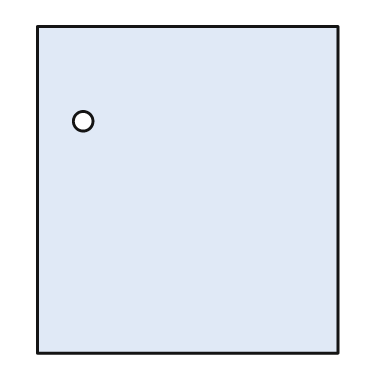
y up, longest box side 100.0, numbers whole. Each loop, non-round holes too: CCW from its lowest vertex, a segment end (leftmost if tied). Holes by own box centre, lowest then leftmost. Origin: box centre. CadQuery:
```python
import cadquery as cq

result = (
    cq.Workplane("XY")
    .moveTo(-46.0, -50.0)
    .lineTo(46.0, -50.0)
    .lineTo(46.0, 50.0)
    .lineTo(-46.0, 50.0)
    .close()
    .moveTo(-32.0, 21.0)
    .circle(3.0)
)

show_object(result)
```